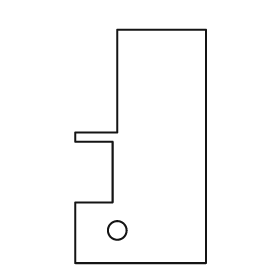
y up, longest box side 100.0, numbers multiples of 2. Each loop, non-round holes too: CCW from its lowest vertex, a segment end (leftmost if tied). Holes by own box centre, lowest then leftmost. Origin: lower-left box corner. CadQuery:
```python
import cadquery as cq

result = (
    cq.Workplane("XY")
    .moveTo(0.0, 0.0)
    .lineTo(56.0, 0.0)
    .lineTo(56.0, 100.0)
    .lineTo(18.0, 100.0)
    .lineTo(18.0, 56.0)
    .lineTo(0.0, 56.0)
    .lineTo(0.0, 52.0)
    .lineTo(16.0, 52.0)
    .lineTo(16.0, 26.0)
    .lineTo(0.0, 26.0)
    .close()
    .moveTo(18.0, 14.0)
    .circle(4.0)
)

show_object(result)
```